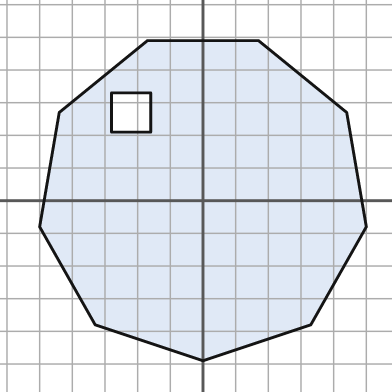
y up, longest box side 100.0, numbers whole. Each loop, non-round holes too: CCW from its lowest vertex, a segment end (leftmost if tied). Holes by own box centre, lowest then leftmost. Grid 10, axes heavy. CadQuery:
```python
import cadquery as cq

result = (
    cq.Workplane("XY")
    .moveTo(0.0, -49.0)
    .lineTo(33.0, -38.0)
    .lineTo(50.0, -8.0)
    .lineTo(44.0, 27.0)
    .lineTo(17.0, 49.0)
    .lineTo(-17.0, 49.0)
    .lineTo(-44.0, 27.0)
    .lineTo(-50.0, -8.0)
    .lineTo(-33.0, -38.0)
    .close()
    .moveTo(-28.0, 21.0)
    .lineTo(-16.0, 21.0)
    .lineTo(-16.0, 33.0)
    .lineTo(-28.0, 33.0)
    .close()
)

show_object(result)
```